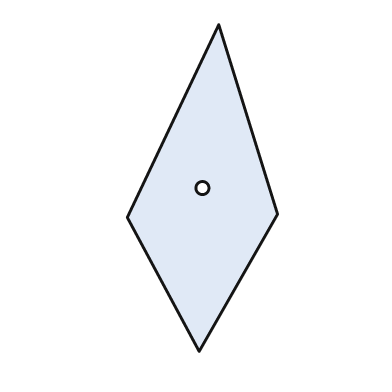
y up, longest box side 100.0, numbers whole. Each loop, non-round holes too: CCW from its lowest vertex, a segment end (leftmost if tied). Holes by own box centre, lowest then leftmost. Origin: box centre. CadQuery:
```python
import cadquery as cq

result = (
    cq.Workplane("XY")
    .moveTo(-1.0, -50.0)
    .lineTo(23.0, -8.0)
    .lineTo(5.0, 50.0)
    .lineTo(-23.0, -9.0)
    .close()
    .moveTo(0.0, 0.0)
    .circle(2.0)
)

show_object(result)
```